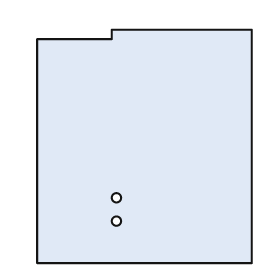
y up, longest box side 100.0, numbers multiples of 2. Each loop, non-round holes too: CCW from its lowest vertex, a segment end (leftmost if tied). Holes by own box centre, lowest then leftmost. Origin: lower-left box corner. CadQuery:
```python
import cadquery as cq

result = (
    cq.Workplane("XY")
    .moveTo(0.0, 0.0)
    .lineTo(92.0, 0.0)
    .lineTo(92.0, 100.0)
    .lineTo(32.0, 100.0)
    .lineTo(32.0, 96.0)
    .lineTo(0.0, 96.0)
    .close()
    .moveTo(34.0, 18.0)
    .circle(2.0)
    .moveTo(34.0, 28.0)
    .circle(2.0)
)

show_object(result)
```